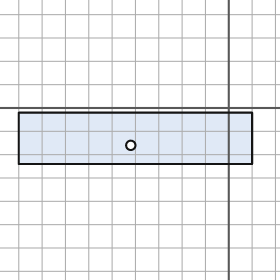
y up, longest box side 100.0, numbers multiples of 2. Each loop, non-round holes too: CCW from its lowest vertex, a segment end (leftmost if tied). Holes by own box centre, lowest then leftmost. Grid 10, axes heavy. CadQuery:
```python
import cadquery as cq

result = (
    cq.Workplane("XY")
    .moveTo(-90.0, -24.0)
    .lineTo(10.0, -24.0)
    .lineTo(10.0, -2.0)
    .lineTo(-90.0, -2.0)
    .close()
    .moveTo(-42.0, -16.0)
    .circle(2.0)
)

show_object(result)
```